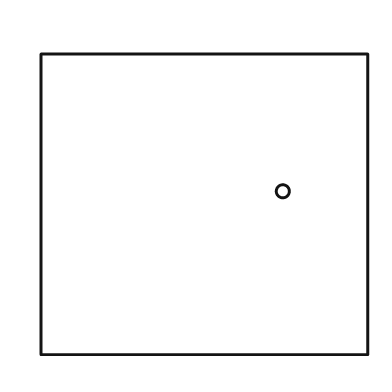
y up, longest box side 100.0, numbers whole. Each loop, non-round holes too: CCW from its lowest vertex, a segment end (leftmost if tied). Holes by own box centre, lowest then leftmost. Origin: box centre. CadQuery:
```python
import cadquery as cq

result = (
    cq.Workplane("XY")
    .moveTo(-50.0, -46.0)
    .lineTo(50.0, -46.0)
    .lineTo(50.0, 46.0)
    .lineTo(-50.0, 46.0)
    .close()
    .moveTo(24.0, 4.0)
    .circle(2.0)
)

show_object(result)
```